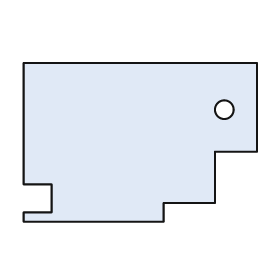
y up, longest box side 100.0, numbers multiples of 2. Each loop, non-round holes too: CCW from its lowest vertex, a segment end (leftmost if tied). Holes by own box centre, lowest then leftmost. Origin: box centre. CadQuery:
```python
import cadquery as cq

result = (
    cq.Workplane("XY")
    .moveTo(-50.0, -34.0)
    .lineTo(10.0, -34.0)
    .lineTo(10.0, -26.0)
    .lineTo(32.0, -26.0)
    .lineTo(32.0, -4.0)
    .lineTo(50.0, -4.0)
    .lineTo(50.0, 34.0)
    .lineTo(-50.0, 34.0)
    .lineTo(-50.0, -18.0)
    .lineTo(-38.0, -18.0)
    .lineTo(-38.0, -30.0)
    .lineTo(-50.0, -30.0)
    .close()
    .moveTo(36.0, 14.0)
    .circle(4.0)
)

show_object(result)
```